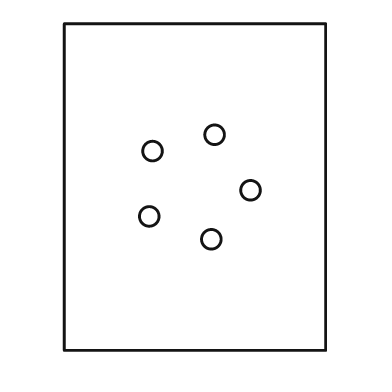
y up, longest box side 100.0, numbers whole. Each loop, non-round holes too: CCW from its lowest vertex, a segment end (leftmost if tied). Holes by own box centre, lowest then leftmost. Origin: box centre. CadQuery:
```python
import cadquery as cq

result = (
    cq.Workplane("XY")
    .moveTo(-40.0, -50.0)
    .lineTo(40.0, -50.0)
    .lineTo(40.0, 50.0)
    .lineTo(-40.0, 50.0)
    .close()
    .moveTo(5.0, -16.0)
    .circle(3.0)
    .moveTo(-14.0, -9.0)
    .circle(3.0)
    .moveTo(17.0, -1.0)
    .circle(3.0)
    .moveTo(-13.0, 11.0)
    .circle(3.0)
    .moveTo(6.0, 16.0)
    .circle(3.0)
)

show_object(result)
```